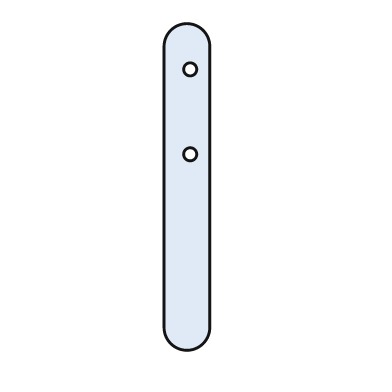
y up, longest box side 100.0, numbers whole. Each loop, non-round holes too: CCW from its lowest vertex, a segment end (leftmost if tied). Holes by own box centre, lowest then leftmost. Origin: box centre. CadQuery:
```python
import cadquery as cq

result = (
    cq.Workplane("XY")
    .moveTo(-7.0, -43.0)
    .threePointArc((0.0, -50.0), (7.0, -43.0))
    .lineTo(7.0, 43.0)
    .threePointArc((0.0, 50.0), (-7.0, 43.0))
    .close()
    .moveTo(1.0, 10.0)
    .circle(2.0)
    .moveTo(1.0, 36.0)
    .circle(2.0)
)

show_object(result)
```